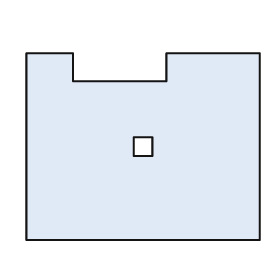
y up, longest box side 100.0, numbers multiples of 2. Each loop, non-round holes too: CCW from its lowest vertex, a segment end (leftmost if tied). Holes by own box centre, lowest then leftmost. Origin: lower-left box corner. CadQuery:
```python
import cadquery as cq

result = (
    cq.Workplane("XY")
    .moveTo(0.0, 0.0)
    .lineTo(100.0, 0.0)
    .lineTo(100.0, 80.0)
    .lineTo(60.0, 80.0)
    .lineTo(60.0, 68.0)
    .lineTo(20.0, 68.0)
    .lineTo(20.0, 80.0)
    .lineTo(0.0, 80.0)
    .close()
    .moveTo(46.0, 36.0)
    .lineTo(54.0, 36.0)
    .lineTo(54.0, 44.0)
    .lineTo(46.0, 44.0)
    .close()
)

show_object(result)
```